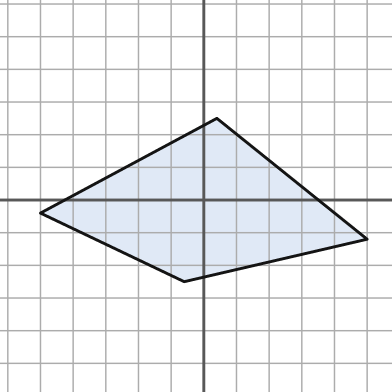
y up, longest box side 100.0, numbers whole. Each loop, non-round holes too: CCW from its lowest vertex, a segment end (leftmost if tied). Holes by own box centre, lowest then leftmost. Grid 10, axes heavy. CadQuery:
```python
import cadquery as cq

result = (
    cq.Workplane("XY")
    .moveTo(-6.0, -25.0)
    .lineTo(50.0, -12.0)
    .lineTo(4.0, 25.0)
    .lineTo(-50.0, -4.0)
    .close()
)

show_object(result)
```